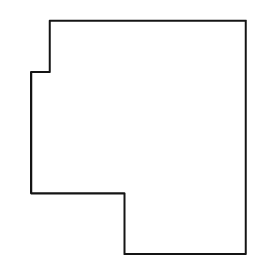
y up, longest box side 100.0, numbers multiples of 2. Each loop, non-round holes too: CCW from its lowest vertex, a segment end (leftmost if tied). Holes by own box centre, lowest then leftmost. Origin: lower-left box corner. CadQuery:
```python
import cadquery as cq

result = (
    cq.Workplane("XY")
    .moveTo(40.0, 0.0)
    .lineTo(92.0, 0.0)
    .lineTo(92.0, 100.0)
    .lineTo(8.0, 100.0)
    .lineTo(8.0, 78.0)
    .lineTo(0.0, 78.0)
    .lineTo(0.0, 26.0)
    .lineTo(40.0, 26.0)
    .close()
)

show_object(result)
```